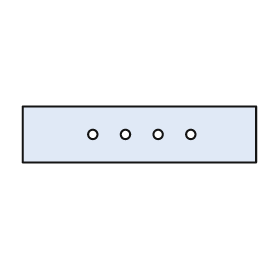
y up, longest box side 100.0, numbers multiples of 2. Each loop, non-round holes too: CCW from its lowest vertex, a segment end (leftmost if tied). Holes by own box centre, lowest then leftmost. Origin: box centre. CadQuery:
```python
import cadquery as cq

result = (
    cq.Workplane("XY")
    .moveTo(-50.0, -12.0)
    .lineTo(50.0, -12.0)
    .lineTo(50.0, 12.0)
    .lineTo(-50.0, 12.0)
    .close()
    .moveTo(-20.0, 0.0)
    .circle(2.0)
    .moveTo(-6.0, 0.0)
    .circle(2.0)
    .moveTo(8.0, 0.0)
    .circle(2.0)
    .moveTo(22.0, 0.0)
    .circle(2.0)
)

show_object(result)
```